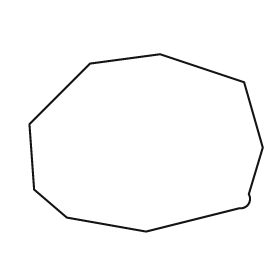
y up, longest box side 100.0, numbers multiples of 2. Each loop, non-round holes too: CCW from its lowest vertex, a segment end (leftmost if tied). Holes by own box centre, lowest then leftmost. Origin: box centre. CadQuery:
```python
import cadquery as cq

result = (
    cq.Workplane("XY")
    .moveTo(0.0, -38.0)
    .lineTo(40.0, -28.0)
    .threePointArc((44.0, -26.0), (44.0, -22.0))
    .lineTo(50.0, -2.0)
    .lineTo(42.0, 26.0)
    .lineTo(6.0, 38.0)
    .lineTo(-24.0, 34.0)
    .lineTo(-50.0, 8.0)
    .lineTo(-48.0, -20.0)
    .lineTo(-34.0, -32.0)
    .close()
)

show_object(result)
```